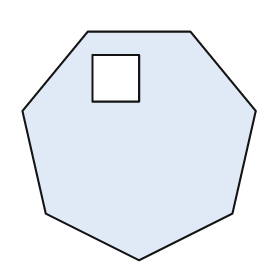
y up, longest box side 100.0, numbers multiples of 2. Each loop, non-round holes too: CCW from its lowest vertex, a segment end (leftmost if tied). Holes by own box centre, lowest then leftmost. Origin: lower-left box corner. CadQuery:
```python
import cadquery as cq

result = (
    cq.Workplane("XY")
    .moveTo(50.0, 0.0)
    .lineTo(90.0, 20.0)
    .lineTo(100.0, 64.0)
    .lineTo(72.0, 98.0)
    .lineTo(28.0, 98.0)
    .lineTo(0.0, 64.0)
    .lineTo(10.0, 20.0)
    .close()
    .moveTo(30.0, 68.0)
    .lineTo(50.0, 68.0)
    .lineTo(50.0, 88.0)
    .lineTo(30.0, 88.0)
    .close()
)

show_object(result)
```